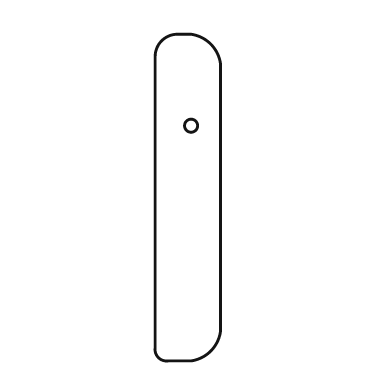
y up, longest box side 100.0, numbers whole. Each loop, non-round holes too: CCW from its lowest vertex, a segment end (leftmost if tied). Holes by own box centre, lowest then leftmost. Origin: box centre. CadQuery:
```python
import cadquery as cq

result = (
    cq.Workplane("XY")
    .moveTo(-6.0, -50.0)
    .lineTo(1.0, -50.0)
    .threePointArc((7.0, -47.0), (10.0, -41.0))
    .lineTo(10.0, 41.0)
    .threePointArc((7.0, 47.0), (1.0, 50.0))
    .lineTo(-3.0, 50.0)
    .threePointArc((-8.0, 48.0), (-10.0, 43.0))
    .lineTo(-10.0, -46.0)
    .threePointArc((-9.0, -49.0), (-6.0, -50.0))
    .close()
    .moveTo(1.0, 22.0)
    .circle(2.0)
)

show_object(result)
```